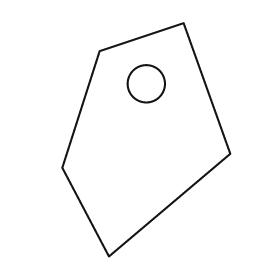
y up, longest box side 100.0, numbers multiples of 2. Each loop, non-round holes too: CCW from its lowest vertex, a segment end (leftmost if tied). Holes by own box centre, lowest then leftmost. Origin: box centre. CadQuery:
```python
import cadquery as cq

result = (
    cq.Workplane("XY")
    .moveTo(-16.0, -50.0)
    .lineTo(36.0, -6.0)
    .lineTo(16.0, 50.0)
    .lineTo(-20.0, 38.0)
    .lineTo(-36.0, -12.0)
    .close()
    .moveTo(0.0, 24.0)
    .circle(8.0)
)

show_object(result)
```